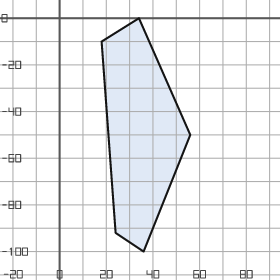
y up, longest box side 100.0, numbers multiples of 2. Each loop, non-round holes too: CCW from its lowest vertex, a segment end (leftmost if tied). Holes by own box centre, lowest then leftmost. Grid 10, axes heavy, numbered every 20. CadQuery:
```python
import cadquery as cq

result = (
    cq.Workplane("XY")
    .moveTo(36.0, -100.0)
    .lineTo(56.0, -50.0)
    .lineTo(34.0, 0.0)
    .lineTo(18.0, -10.0)
    .lineTo(24.0, -92.0)
    .close()
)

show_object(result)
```